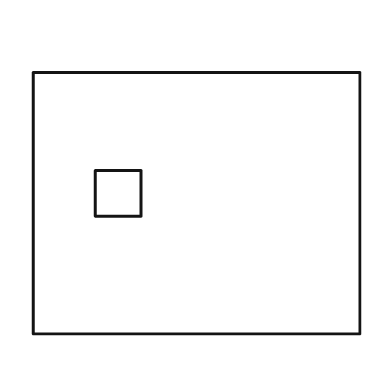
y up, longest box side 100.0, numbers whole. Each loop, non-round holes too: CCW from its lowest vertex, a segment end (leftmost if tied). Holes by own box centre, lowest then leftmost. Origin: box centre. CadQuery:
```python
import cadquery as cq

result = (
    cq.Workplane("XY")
    .moveTo(-50.0, -40.0)
    .lineTo(50.0, -40.0)
    .lineTo(50.0, 40.0)
    .lineTo(-50.0, 40.0)
    .close()
    .moveTo(-31.0, -4.0)
    .lineTo(-17.0, -4.0)
    .lineTo(-17.0, 10.0)
    .lineTo(-31.0, 10.0)
    .close()
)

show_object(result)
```